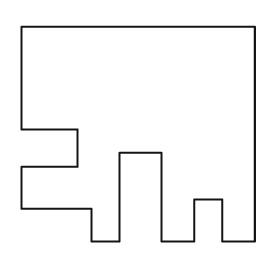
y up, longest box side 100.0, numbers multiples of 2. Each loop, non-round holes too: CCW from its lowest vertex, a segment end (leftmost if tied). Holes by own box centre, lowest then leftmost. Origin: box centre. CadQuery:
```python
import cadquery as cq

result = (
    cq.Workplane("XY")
    .moveTo(-20.0, -46.0)
    .lineTo(-8.0, -46.0)
    .lineTo(-8.0, -8.0)
    .lineTo(10.0, -8.0)
    .lineTo(10.0, -46.0)
    .lineTo(24.0, -46.0)
    .lineTo(24.0, -28.0)
    .lineTo(36.0, -28.0)
    .lineTo(36.0, -46.0)
    .lineTo(50.0, -46.0)
    .lineTo(50.0, 46.0)
    .lineTo(-50.0, 46.0)
    .lineTo(-50.0, 2.0)
    .lineTo(-26.0, 2.0)
    .lineTo(-26.0, -14.0)
    .lineTo(-50.0, -14.0)
    .lineTo(-50.0, -32.0)
    .lineTo(-20.0, -32.0)
    .close()
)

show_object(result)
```